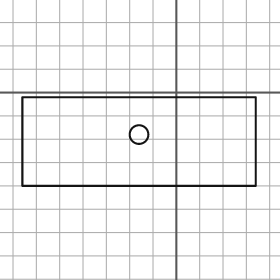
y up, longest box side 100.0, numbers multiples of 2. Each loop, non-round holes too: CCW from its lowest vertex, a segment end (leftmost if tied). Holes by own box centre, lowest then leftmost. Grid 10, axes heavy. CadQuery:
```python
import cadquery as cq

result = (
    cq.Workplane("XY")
    .moveTo(-66.0, -40.0)
    .lineTo(34.0, -40.0)
    .lineTo(34.0, -2.0)
    .lineTo(-66.0, -2.0)
    .close()
    .moveTo(-16.0, -18.0)
    .circle(4.0)
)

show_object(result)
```